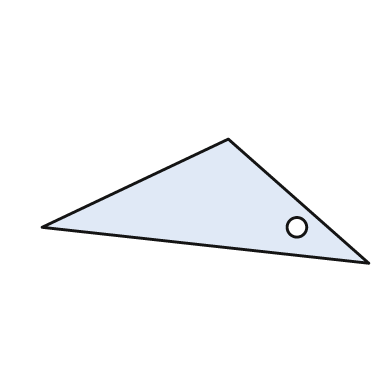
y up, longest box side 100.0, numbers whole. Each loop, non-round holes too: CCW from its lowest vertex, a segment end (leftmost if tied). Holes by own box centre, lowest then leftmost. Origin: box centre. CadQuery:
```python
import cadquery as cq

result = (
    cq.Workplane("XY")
    .moveTo(50.0, -19.0)
    .lineTo(7.0, 19.0)
    .lineTo(-50.0, -8.0)
    .close()
    .moveTo(28.0, -8.0)
    .circle(3.0)
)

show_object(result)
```